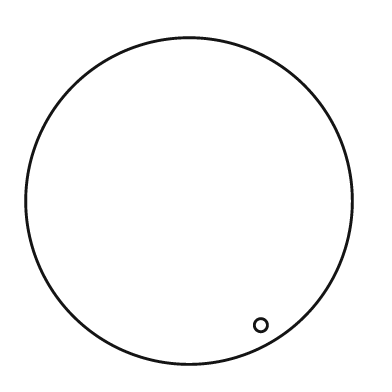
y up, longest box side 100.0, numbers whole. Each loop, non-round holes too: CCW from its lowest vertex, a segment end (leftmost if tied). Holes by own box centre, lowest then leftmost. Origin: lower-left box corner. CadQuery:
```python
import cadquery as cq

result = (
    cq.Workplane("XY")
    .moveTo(50.0, 50.0)
    .circle(50.0)
    .moveTo(72.0, 12.0)
    .circle(2.0)
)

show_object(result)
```